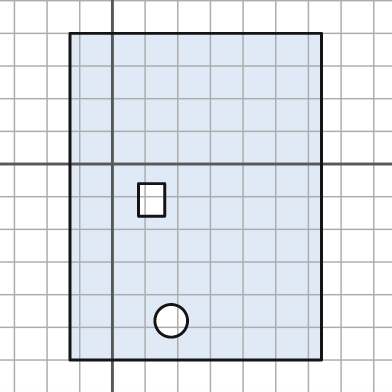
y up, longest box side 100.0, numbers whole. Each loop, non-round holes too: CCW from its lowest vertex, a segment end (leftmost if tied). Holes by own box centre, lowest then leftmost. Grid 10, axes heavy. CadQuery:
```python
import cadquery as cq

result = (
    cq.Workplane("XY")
    .moveTo(-13.0, -60.0)
    .lineTo(64.0, -60.0)
    .lineTo(64.0, 40.0)
    .lineTo(-13.0, 40.0)
    .close()
    .moveTo(18.0, -48.0)
    .circle(5.0)
    .moveTo(8.0, -16.0)
    .lineTo(16.0, -16.0)
    .lineTo(16.0, -6.0)
    .lineTo(8.0, -6.0)
    .close()
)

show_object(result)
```